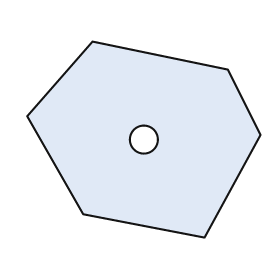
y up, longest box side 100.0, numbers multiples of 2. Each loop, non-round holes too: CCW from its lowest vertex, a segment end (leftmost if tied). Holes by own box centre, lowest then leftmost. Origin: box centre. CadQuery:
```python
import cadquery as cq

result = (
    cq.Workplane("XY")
    .moveTo(26.0, -42.0)
    .lineTo(50.0, 2.0)
    .lineTo(36.0, 30.0)
    .lineTo(-22.0, 42.0)
    .lineTo(-50.0, 10.0)
    .lineTo(-26.0, -32.0)
    .close()
    .moveTo(0.0, 0.0)
    .circle(6.0)
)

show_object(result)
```